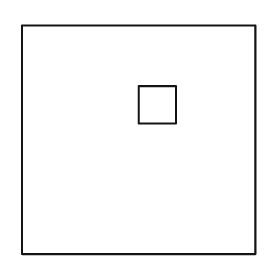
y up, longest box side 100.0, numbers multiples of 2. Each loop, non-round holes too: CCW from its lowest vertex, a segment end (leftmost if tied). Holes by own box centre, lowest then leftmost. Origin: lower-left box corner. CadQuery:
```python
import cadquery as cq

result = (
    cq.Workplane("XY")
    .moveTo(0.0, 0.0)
    .lineTo(100.0, 0.0)
    .lineTo(100.0, 98.0)
    .lineTo(0.0, 98.0)
    .close()
    .moveTo(50.0, 56.0)
    .lineTo(66.0, 56.0)
    .lineTo(66.0, 72.0)
    .lineTo(50.0, 72.0)
    .close()
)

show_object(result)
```